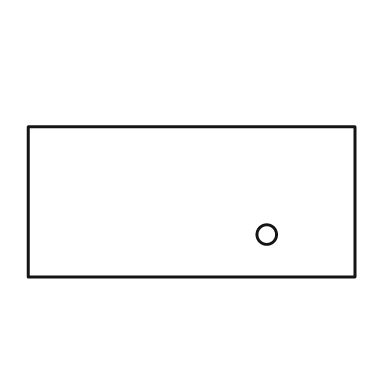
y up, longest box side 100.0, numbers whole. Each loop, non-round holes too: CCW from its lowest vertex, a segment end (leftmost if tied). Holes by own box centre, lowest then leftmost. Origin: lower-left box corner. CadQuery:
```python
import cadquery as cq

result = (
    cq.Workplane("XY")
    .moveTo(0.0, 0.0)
    .lineTo(100.0, 0.0)
    .lineTo(100.0, 46.0)
    .lineTo(0.0, 46.0)
    .close()
    .moveTo(73.0, 13.0)
    .circle(3.0)
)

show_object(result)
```